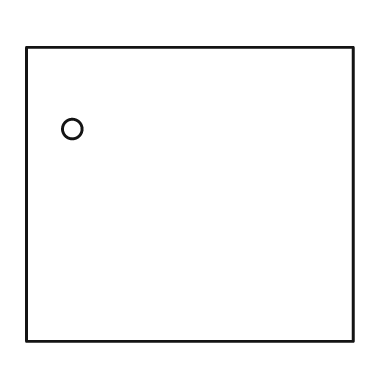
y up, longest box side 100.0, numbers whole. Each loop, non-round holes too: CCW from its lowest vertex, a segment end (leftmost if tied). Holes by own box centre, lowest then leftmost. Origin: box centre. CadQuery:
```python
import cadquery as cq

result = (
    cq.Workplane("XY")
    .moveTo(-50.0, -45.0)
    .lineTo(50.0, -45.0)
    .lineTo(50.0, 45.0)
    .lineTo(-50.0, 45.0)
    .close()
    .moveTo(-36.0, 20.0)
    .circle(3.0)
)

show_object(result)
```